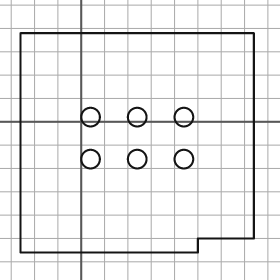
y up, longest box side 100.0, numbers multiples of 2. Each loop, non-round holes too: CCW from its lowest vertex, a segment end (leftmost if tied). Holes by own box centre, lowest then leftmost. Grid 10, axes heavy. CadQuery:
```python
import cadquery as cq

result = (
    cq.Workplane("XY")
    .moveTo(-26.0, -56.0)
    .lineTo(50.0, -56.0)
    .lineTo(50.0, -50.0)
    .lineTo(74.0, -50.0)
    .lineTo(74.0, 38.0)
    .lineTo(-26.0, 38.0)
    .close()
    .moveTo(4.0, -16.0)
    .circle(4.0)
    .moveTo(24.0, -16.0)
    .circle(4.0)
    .moveTo(44.0, -16.0)
    .circle(4.0)
    .moveTo(4.0, 2.0)
    .circle(4.0)
    .moveTo(24.0, 2.0)
    .circle(4.0)
    .moveTo(44.0, 2.0)
    .circle(4.0)
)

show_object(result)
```